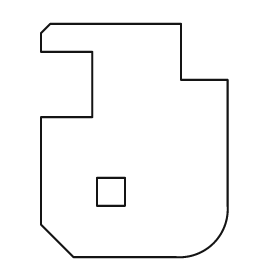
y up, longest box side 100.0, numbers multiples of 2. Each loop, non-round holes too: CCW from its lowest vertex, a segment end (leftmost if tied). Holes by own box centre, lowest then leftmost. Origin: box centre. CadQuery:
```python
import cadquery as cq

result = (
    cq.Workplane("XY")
    .moveTo(-26.0, -50.0)
    .lineTo(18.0, -50.0)
    .threePointArc((34.0, -44.0), (40.0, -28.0))
    .lineTo(40.0, 26.0)
    .lineTo(20.0, 26.0)
    .lineTo(20.0, 50.0)
    .lineTo(-36.0, 50.0)
    .lineTo(-40.0, 46.0)
    .lineTo(-40.0, 38.0)
    .lineTo(-18.0, 38.0)
    .lineTo(-18.0, 10.0)
    .lineTo(-40.0, 10.0)
    .lineTo(-40.0, -36.0)
    .close()
    .moveTo(-16.0, -28.0)
    .lineTo(-4.0, -28.0)
    .lineTo(-4.0, -16.0)
    .lineTo(-16.0, -16.0)
    .close()
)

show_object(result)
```